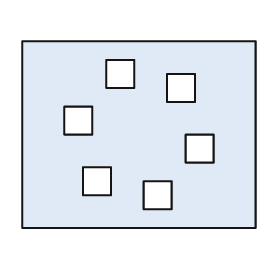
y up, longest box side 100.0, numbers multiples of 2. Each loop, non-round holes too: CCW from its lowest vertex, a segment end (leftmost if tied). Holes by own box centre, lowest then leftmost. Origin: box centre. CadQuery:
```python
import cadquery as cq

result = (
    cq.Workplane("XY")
    .moveTo(-50.0, -40.0)
    .lineTo(50.0, -40.0)
    .lineTo(50.0, 40.0)
    .lineTo(-50.0, 40.0)
    .close()
    .moveTo(2.0, -32.0)
    .lineTo(14.0, -32.0)
    .lineTo(14.0, -20.0)
    .lineTo(2.0, -20.0)
    .close()
    .moveTo(-24.0, -26.0)
    .lineTo(-12.0, -26.0)
    .lineTo(-12.0, -14.0)
    .lineTo(-24.0, -14.0)
    .close()
    .moveTo(20.0, -12.0)
    .lineTo(32.0, -12.0)
    .lineTo(32.0, 0.0)
    .lineTo(20.0, 0.0)
    .close()
    .moveTo(-32.0, 0.0)
    .lineTo(-20.0, 0.0)
    .lineTo(-20.0, 12.0)
    .lineTo(-32.0, 12.0)
    .close()
    .moveTo(12.0, 14.0)
    .lineTo(24.0, 14.0)
    .lineTo(24.0, 26.0)
    .lineTo(12.0, 26.0)
    .close()
    .moveTo(-14.0, 20.0)
    .lineTo(-2.0, 20.0)
    .lineTo(-2.0, 32.0)
    .lineTo(-14.0, 32.0)
    .close()
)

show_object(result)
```